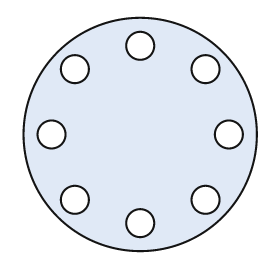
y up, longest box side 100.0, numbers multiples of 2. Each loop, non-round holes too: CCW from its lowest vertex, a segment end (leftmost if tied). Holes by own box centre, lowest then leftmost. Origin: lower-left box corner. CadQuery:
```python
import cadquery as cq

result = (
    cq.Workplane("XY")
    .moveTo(50.0, 50.0)
    .circle(50.0)
    .moveTo(50.0, 12.0)
    .circle(6.0)
    .moveTo(22.0, 22.0)
    .circle(6.0)
    .moveTo(78.0, 22.0)
    .circle(6.0)
    .moveTo(12.0, 50.0)
    .circle(6.0)
    .moveTo(88.0, 50.0)
    .circle(6.0)
    .moveTo(22.0, 78.0)
    .circle(6.0)
    .moveTo(78.0, 78.0)
    .circle(6.0)
    .moveTo(50.0, 88.0)
    .circle(6.0)
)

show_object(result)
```